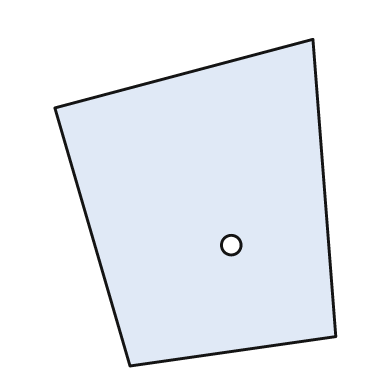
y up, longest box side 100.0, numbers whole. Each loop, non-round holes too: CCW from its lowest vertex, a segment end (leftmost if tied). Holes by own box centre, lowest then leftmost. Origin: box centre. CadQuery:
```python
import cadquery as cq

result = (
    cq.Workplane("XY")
    .moveTo(-20.0, -50.0)
    .lineTo(43.0, -41.0)
    .lineTo(36.0, 50.0)
    .lineTo(-43.0, 29.0)
    .close()
    .moveTo(11.0, -13.0)
    .circle(3.0)
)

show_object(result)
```